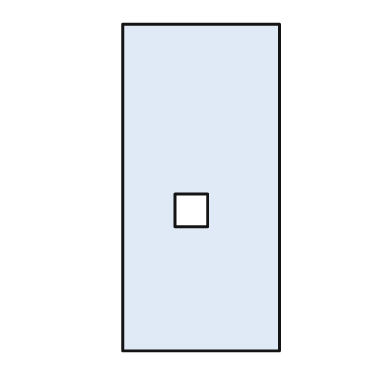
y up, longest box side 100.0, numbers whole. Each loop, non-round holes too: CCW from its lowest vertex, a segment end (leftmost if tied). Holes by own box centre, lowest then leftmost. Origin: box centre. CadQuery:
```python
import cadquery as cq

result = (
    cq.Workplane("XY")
    .moveTo(-24.0, -50.0)
    .lineTo(24.0, -50.0)
    .lineTo(24.0, 50.0)
    .lineTo(-24.0, 50.0)
    .close()
    .moveTo(-8.0, -12.0)
    .lineTo(2.0, -12.0)
    .lineTo(2.0, -2.0)
    .lineTo(-8.0, -2.0)
    .close()
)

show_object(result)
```